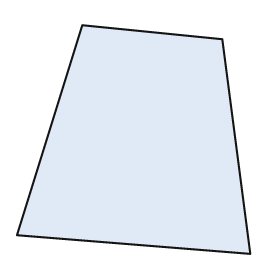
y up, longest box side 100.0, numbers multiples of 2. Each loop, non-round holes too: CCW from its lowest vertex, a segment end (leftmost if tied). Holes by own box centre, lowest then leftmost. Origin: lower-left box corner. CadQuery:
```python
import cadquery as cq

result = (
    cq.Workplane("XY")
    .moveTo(100.0, 0.0)
    .lineTo(88.0, 92.0)
    .lineTo(28.0, 98.0)
    .lineTo(0.0, 8.0)
    .close()
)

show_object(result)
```